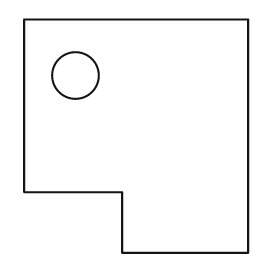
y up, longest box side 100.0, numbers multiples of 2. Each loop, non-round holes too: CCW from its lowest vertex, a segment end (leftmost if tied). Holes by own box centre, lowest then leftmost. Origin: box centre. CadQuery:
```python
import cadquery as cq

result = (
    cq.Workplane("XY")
    .moveTo(-6.0, -50.0)
    .lineTo(48.0, -50.0)
    .lineTo(48.0, 50.0)
    .lineTo(-48.0, 50.0)
    .lineTo(-48.0, -24.0)
    .lineTo(-6.0, -24.0)
    .close()
    .moveTo(-26.0, 26.0)
    .circle(10.0)
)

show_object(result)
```